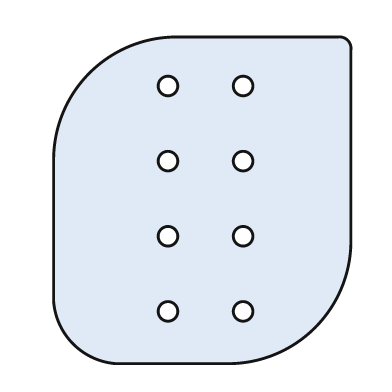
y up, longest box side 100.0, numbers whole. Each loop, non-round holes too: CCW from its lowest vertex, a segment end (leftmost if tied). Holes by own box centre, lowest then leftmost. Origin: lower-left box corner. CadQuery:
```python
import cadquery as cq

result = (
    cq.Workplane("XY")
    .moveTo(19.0, 0.0)
    .lineTo(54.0, 0.0)
    .threePointArc((80.0, 11.0), (91.0, 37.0))
    .lineTo(91.0, 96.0)
    .threePointArc((90.0, 99.0), (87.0, 100.0))
    .lineTo(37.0, 100.0)
    .threePointArc((11.0, 89.0), (0.0, 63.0))
    .lineTo(0.0, 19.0)
    .threePointArc((6.0, 6.0), (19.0, 0.0))
    .close()
    .moveTo(35.0, 16.0)
    .circle(3.0)
    .moveTo(58.0, 16.0)
    .circle(3.0)
    .moveTo(35.0, 39.0)
    .circle(3.0)
    .moveTo(58.0, 39.0)
    .circle(3.0)
    .moveTo(35.0, 62.0)
    .circle(3.0)
    .moveTo(58.0, 62.0)
    .circle(3.0)
    .moveTo(35.0, 85.0)
    .circle(3.0)
    .moveTo(58.0, 85.0)
    .circle(3.0)
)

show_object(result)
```